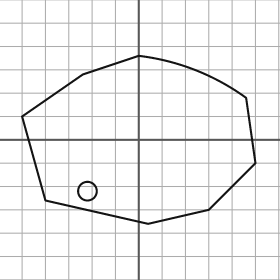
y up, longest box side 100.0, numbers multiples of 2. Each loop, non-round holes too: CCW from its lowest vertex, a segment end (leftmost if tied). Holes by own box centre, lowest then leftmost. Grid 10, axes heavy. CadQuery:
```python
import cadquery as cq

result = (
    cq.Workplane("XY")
    .moveTo(4.0, -36.0)
    .lineTo(30.0, -30.0)
    .lineTo(50.0, -10.0)
    .lineTo(46.0, 18.0)
    .threePointArc((24.0, 30.0), (0.0, 36.0))
    .lineTo(-24.0, 28.0)
    .lineTo(-50.0, 10.0)
    .lineTo(-40.0, -26.0)
    .close()
    .moveTo(-22.0, -22.0)
    .circle(4.0)
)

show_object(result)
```